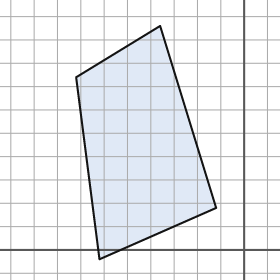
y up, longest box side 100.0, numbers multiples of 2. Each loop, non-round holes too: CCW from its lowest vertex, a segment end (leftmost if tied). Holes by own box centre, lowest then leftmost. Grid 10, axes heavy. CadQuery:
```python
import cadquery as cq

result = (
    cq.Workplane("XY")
    .moveTo(-62.0, -4.0)
    .lineTo(-12.0, 18.0)
    .lineTo(-36.0, 96.0)
    .lineTo(-72.0, 74.0)
    .close()
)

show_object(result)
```